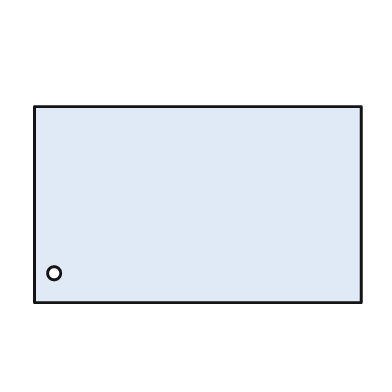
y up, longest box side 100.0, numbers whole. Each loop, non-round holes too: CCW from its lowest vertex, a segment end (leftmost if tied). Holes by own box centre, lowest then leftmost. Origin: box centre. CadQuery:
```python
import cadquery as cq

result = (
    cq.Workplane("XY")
    .moveTo(-50.0, -30.0)
    .lineTo(50.0, -30.0)
    .lineTo(50.0, 30.0)
    .lineTo(-50.0, 30.0)
    .close()
    .moveTo(-44.0, -21.0)
    .circle(2.0)
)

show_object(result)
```